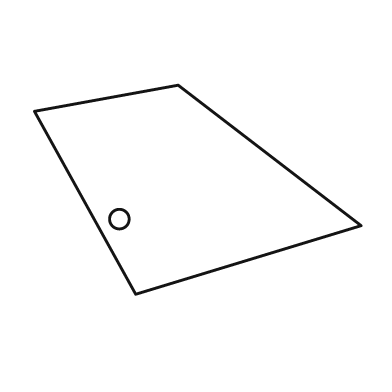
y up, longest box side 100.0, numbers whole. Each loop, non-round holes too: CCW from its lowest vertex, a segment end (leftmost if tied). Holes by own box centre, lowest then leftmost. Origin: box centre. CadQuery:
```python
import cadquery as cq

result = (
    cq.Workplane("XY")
    .moveTo(-19.0, -32.0)
    .lineTo(50.0, -11.0)
    .lineTo(-6.0, 32.0)
    .lineTo(-50.0, 24.0)
    .close()
    .moveTo(-24.0, -9.0)
    .circle(3.0)
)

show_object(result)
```